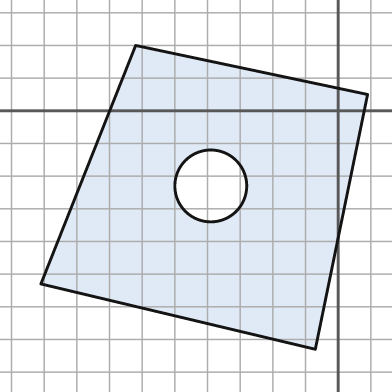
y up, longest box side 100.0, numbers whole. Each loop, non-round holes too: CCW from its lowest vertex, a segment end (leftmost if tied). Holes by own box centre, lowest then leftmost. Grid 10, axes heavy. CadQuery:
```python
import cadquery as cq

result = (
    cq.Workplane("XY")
    .moveTo(-7.0, -73.0)
    .lineTo(9.0, 5.0)
    .lineTo(-62.0, 20.0)
    .lineTo(-91.0, -53.0)
    .close()
    .moveTo(-39.0, -23.0)
    .circle(11.0)
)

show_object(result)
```